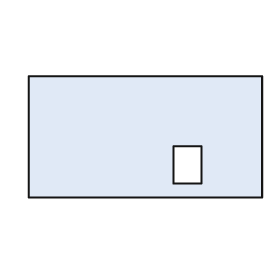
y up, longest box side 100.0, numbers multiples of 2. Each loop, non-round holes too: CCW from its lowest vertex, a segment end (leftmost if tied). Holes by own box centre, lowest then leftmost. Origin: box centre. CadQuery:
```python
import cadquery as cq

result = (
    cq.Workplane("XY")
    .moveTo(-50.0, -26.0)
    .lineTo(50.0, -26.0)
    .lineTo(50.0, 26.0)
    .lineTo(-50.0, 26.0)
    .close()
    .moveTo(12.0, -20.0)
    .lineTo(24.0, -20.0)
    .lineTo(24.0, -4.0)
    .lineTo(12.0, -4.0)
    .close()
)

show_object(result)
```